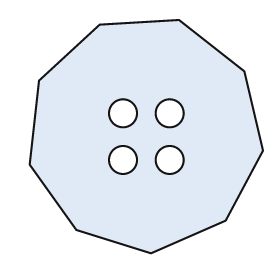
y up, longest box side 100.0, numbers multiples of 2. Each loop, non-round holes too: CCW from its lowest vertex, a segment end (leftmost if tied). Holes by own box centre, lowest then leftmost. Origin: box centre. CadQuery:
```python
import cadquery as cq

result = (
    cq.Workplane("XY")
    .moveTo(2.0, -50.0)
    .lineTo(34.0, -36.0)
    .lineTo(50.0, -6.0)
    .lineTo(42.0, 28.0)
    .lineTo(14.0, 50.0)
    .lineTo(-20.0, 48.0)
    .lineTo(-46.0, 24.0)
    .lineTo(-50.0, -12.0)
    .lineTo(-30.0, -40.0)
    .close()
    .moveTo(-10.0, -10.0)
    .circle(6.0)
    .moveTo(10.0, -10.0)
    .circle(6.0)
    .moveTo(-10.0, 10.0)
    .circle(6.0)
    .moveTo(10.0, 10.0)
    .circle(6.0)
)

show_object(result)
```